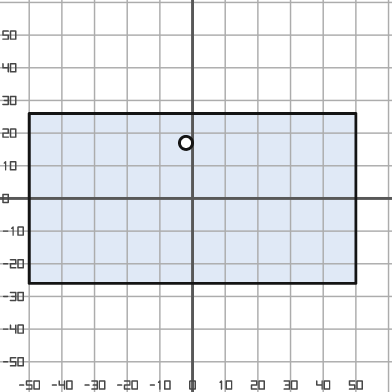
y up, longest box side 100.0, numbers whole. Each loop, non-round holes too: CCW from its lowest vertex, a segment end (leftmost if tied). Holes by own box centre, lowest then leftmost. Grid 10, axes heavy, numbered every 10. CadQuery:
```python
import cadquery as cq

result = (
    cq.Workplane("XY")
    .moveTo(-50.0, -26.0)
    .lineTo(50.0, -26.0)
    .lineTo(50.0, 26.0)
    .lineTo(-50.0, 26.0)
    .close()
    .moveTo(-2.0, 17.0)
    .circle(2.0)
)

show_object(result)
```